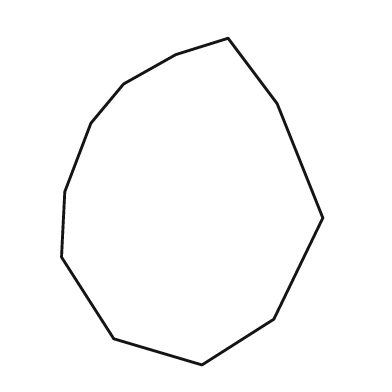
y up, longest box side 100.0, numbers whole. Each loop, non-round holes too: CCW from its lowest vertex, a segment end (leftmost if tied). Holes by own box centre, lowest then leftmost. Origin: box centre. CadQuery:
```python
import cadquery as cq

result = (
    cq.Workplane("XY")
    .moveTo(3.0, -50.0)
    .lineTo(25.0, -36.0)
    .lineTo(40.0, -5.0)
    .lineTo(26.0, 30.0)
    .lineTo(11.0, 50.0)
    .lineTo(-5.0, 45.0)
    .lineTo(-21.0, 36.0)
    .lineTo(-31.0, 24.0)
    .lineTo(-39.0, 3.0)
    .lineTo(-40.0, -17.0)
    .lineTo(-24.0, -42.0)
    .close()
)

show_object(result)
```